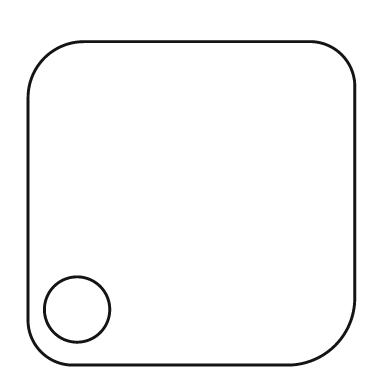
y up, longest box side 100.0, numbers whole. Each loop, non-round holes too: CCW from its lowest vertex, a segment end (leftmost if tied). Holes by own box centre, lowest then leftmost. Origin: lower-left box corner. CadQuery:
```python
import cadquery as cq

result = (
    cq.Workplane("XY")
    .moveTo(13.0, 0.0)
    .lineTo(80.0, 0.0)
    .threePointArc((94.0, 6.0), (100.0, 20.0))
    .lineTo(100.0, 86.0)
    .threePointArc((96.0, 95.0), (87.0, 99.0))
    .lineTo(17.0, 99.0)
    .threePointArc((5.0, 94.0), (0.0, 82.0))
    .lineTo(0.0, 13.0)
    .threePointArc((4.0, 4.0), (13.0, 0.0))
    .close()
    .moveTo(15.0, 17.0)
    .circle(10.0)
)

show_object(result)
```